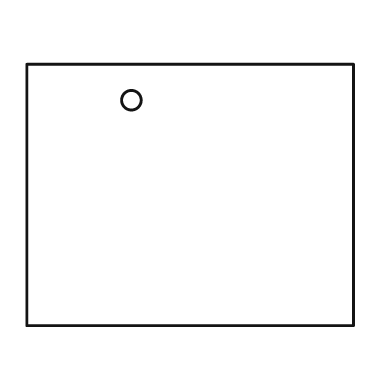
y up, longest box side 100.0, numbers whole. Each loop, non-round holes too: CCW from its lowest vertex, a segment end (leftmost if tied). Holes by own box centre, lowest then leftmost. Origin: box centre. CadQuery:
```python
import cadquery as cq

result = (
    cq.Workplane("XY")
    .moveTo(-50.0, -40.0)
    .lineTo(50.0, -40.0)
    .lineTo(50.0, 40.0)
    .lineTo(-50.0, 40.0)
    .close()
    .moveTo(-18.0, 29.0)
    .circle(3.0)
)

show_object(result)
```